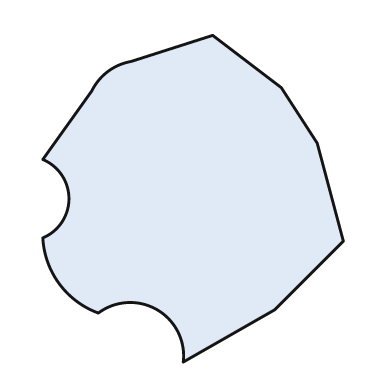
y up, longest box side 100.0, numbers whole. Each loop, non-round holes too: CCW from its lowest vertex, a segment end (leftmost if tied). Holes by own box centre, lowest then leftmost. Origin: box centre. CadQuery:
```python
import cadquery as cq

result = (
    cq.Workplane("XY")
    .moveTo(-3.0, -50.0)
    .lineTo(25.0, -34.0)
    .lineTo(46.0, -13.0)
    .lineTo(38.0, 17.0)
    .lineTo(27.0, 34.0)
    .lineTo(6.0, 50.0)
    .lineTo(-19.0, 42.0)
    .threePointArc((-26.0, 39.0), (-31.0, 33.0))
    .lineTo(-46.0, 12.0)
    .threePointArc((-38.0, 0.0), (-46.0, -12.0))
    .threePointArc((-41.0, -26.0), (-29.0, -35.0))
    .threePointArc((-11.0, -34.0), (-3.0, -50.0))
    .close()
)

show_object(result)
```